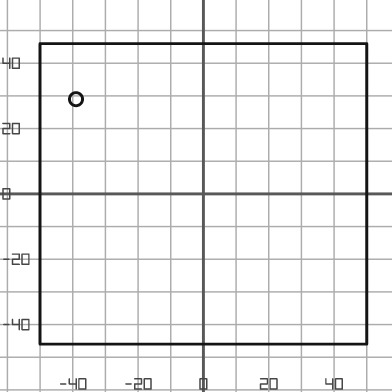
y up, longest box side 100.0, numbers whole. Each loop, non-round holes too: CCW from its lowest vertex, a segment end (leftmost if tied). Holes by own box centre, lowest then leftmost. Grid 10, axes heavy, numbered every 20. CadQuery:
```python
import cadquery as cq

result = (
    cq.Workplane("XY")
    .moveTo(-50.0, -46.0)
    .lineTo(50.0, -46.0)
    .lineTo(50.0, 46.0)
    .lineTo(-50.0, 46.0)
    .close()
    .moveTo(-39.0, 29.0)
    .circle(2.0)
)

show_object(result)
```